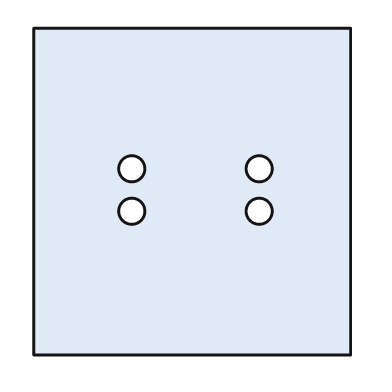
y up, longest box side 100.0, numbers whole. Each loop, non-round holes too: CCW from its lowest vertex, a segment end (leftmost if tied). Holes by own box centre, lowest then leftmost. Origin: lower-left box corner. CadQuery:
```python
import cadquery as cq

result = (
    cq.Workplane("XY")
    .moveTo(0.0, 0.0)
    .lineTo(97.0, 0.0)
    .lineTo(97.0, 100.0)
    .lineTo(0.0, 100.0)
    .close()
    .moveTo(30.0, 44.0)
    .circle(4.0)
    .moveTo(69.0, 44.0)
    .circle(4.0)
    .moveTo(30.0, 57.0)
    .circle(4.0)
    .moveTo(69.0, 57.0)
    .circle(4.0)
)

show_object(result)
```